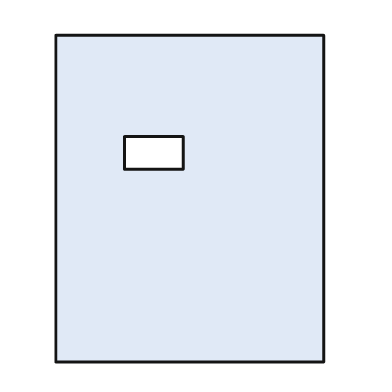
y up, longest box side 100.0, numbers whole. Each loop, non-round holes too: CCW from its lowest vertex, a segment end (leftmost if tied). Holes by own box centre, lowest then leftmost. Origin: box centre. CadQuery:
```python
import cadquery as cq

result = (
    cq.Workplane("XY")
    .moveTo(-41.0, -50.0)
    .lineTo(41.0, -50.0)
    .lineTo(41.0, 50.0)
    .lineTo(-41.0, 50.0)
    .close()
    .moveTo(-20.0, 9.0)
    .lineTo(-2.0, 9.0)
    .lineTo(-2.0, 19.0)
    .lineTo(-20.0, 19.0)
    .close()
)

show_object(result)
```